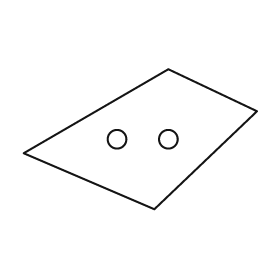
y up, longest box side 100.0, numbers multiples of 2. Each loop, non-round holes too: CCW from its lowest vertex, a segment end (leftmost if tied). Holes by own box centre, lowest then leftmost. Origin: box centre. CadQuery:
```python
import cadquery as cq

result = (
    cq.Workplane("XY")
    .moveTo(6.0, -30.0)
    .lineTo(50.0, 12.0)
    .lineTo(12.0, 30.0)
    .lineTo(-50.0, -6.0)
    .close()
    .moveTo(-10.0, 0.0)
    .circle(4.0)
    .moveTo(12.0, 0.0)
    .circle(4.0)
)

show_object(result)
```